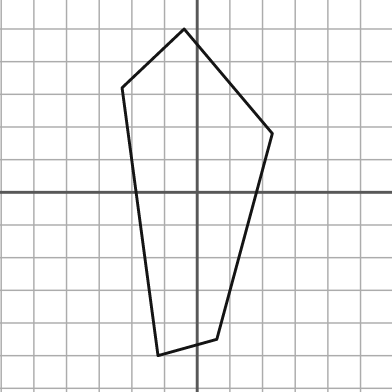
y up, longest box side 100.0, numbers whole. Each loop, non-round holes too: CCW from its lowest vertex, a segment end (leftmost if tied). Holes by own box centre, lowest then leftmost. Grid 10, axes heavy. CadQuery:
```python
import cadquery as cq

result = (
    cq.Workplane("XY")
    .moveTo(-12.0, -50.0)
    .lineTo(6.0, -45.0)
    .lineTo(23.0, 18.0)
    .lineTo(-4.0, 50.0)
    .lineTo(-23.0, 32.0)
    .close()
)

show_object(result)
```